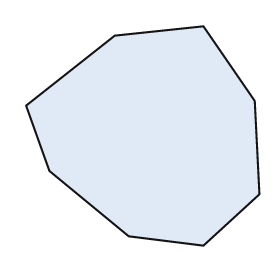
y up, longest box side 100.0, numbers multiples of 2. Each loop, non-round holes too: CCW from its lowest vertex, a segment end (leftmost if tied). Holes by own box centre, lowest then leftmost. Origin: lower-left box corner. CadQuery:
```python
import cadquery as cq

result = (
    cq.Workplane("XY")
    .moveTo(76.0, 0.0)
    .lineTo(100.0, 22.0)
    .lineTo(98.0, 62.0)
    .lineTo(76.0, 94.0)
    .lineTo(38.0, 90.0)
    .lineTo(0.0, 60.0)
    .lineTo(10.0, 32.0)
    .lineTo(44.0, 4.0)
    .close()
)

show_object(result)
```